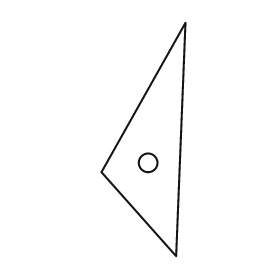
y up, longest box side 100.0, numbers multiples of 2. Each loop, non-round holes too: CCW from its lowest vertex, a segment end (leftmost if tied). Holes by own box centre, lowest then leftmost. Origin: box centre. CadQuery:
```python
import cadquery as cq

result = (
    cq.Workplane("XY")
    .moveTo(14.0, -50.0)
    .lineTo(18.0, 50.0)
    .lineTo(-18.0, -14.0)
    .close()
    .moveTo(2.0, -10.0)
    .circle(4.0)
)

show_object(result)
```